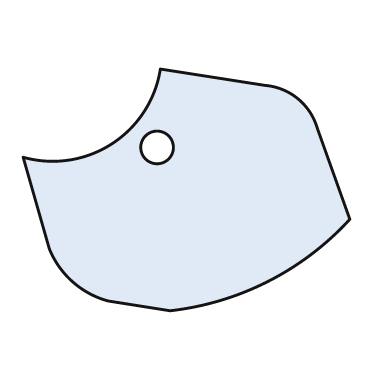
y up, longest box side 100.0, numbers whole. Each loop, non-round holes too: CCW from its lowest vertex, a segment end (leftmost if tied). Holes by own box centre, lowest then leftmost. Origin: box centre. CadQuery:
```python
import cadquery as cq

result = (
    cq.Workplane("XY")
    .moveTo(-5.0, -37.0)
    .threePointArc((25.0, -28.0), (50.0, -9.0))
    .lineTo(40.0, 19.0)
    .threePointArc((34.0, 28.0), (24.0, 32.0))
    .lineTo(-8.0, 37.0)
    .threePointArc((-23.0, 14.0), (-50.0, 10.0))
    .lineTo(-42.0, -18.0)
    .threePointArc((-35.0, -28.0), (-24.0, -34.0))
    .close()
    .moveTo(-9.0, 13.0)
    .circle(5.0)
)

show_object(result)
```